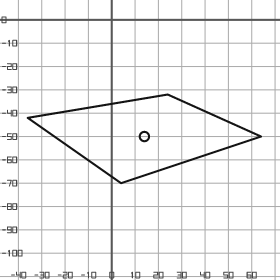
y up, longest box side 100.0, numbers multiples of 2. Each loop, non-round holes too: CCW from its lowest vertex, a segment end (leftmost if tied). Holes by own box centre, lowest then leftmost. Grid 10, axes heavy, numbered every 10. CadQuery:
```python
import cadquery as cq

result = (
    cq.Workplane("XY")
    .moveTo(4.0, -70.0)
    .lineTo(64.0, -50.0)
    .lineTo(24.0, -32.0)
    .lineTo(-36.0, -42.0)
    .close()
    .moveTo(14.0, -50.0)
    .circle(2.0)
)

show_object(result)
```